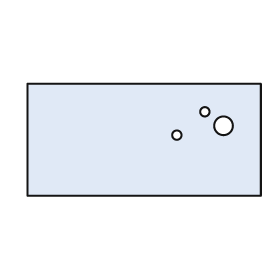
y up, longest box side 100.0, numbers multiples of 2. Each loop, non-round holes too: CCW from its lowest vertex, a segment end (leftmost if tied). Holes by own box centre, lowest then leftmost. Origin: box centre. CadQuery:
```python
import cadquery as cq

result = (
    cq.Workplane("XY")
    .moveTo(-50.0, -24.0)
    .lineTo(50.0, -24.0)
    .lineTo(50.0, 24.0)
    .lineTo(-50.0, 24.0)
    .close()
    .moveTo(14.0, 2.0)
    .circle(2.0)
    .moveTo(34.0, 6.0)
    .circle(4.0)
    .moveTo(26.0, 12.0)
    .circle(2.0)
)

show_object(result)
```